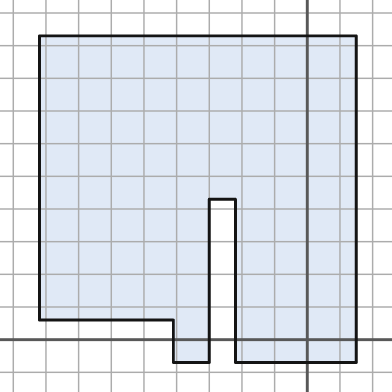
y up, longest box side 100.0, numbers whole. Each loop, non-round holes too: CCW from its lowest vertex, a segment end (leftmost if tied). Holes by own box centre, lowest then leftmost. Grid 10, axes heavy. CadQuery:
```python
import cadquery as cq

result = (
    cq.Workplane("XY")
    .moveTo(-41.0, -7.0)
    .lineTo(-30.0, -7.0)
    .lineTo(-30.0, 43.0)
    .lineTo(-22.0, 43.0)
    .lineTo(-22.0, -7.0)
    .lineTo(15.0, -7.0)
    .lineTo(15.0, 93.0)
    .lineTo(-82.0, 93.0)
    .lineTo(-82.0, 6.0)
    .lineTo(-41.0, 6.0)
    .close()
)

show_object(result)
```